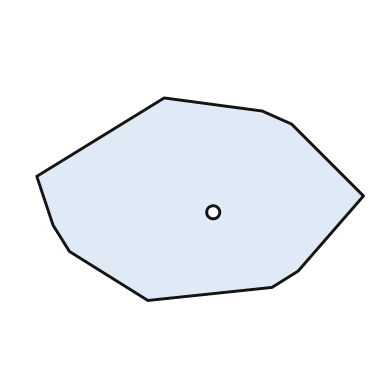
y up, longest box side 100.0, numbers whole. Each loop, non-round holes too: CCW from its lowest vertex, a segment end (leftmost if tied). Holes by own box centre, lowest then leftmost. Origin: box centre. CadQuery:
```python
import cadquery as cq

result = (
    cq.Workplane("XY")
    .moveTo(-16.0, -31.0)
    .lineTo(22.0, -27.0)
    .lineTo(30.0, -22.0)
    .lineTo(50.0, 1.0)
    .lineTo(28.0, 23.0)
    .lineTo(19.0, 27.0)
    .lineTo(-11.0, 31.0)
    .lineTo(-50.0, 7.0)
    .lineTo(-45.0, -8.0)
    .lineTo(-40.0, -16.0)
    .close()
    .moveTo(4.0, -4.0)
    .circle(2.0)
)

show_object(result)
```